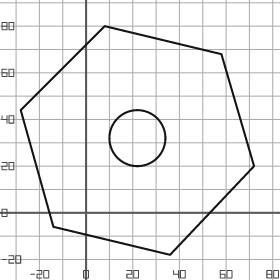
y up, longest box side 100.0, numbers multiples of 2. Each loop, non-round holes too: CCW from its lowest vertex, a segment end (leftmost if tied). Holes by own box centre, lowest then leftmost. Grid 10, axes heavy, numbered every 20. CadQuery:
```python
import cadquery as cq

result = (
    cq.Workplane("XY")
    .moveTo(36.0, -18.0)
    .lineTo(72.0, 20.0)
    .lineTo(58.0, 68.0)
    .lineTo(8.0, 80.0)
    .lineTo(-28.0, 44.0)
    .lineTo(-14.0, -6.0)
    .close()
    .moveTo(22.0, 32.0)
    .circle(12.0)
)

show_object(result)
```